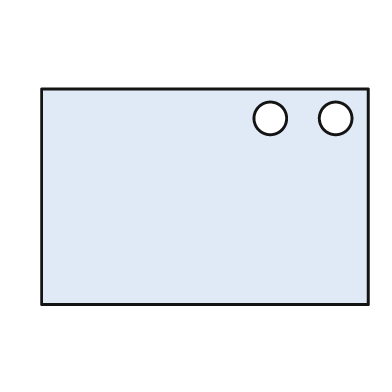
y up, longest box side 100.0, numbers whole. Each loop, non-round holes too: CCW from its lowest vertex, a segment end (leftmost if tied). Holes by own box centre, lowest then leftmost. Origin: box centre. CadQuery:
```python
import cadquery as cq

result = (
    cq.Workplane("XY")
    .moveTo(-50.0, -33.0)
    .lineTo(50.0, -33.0)
    .lineTo(50.0, 33.0)
    .lineTo(-50.0, 33.0)
    .close()
    .moveTo(20.0, 24.0)
    .circle(5.0)
    .moveTo(40.0, 24.0)
    .circle(5.0)
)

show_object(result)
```